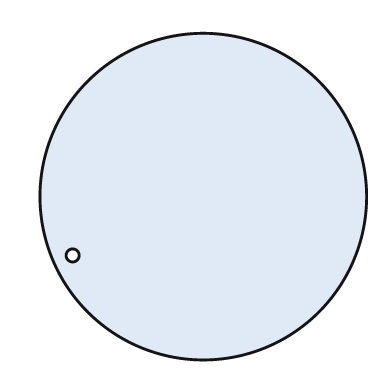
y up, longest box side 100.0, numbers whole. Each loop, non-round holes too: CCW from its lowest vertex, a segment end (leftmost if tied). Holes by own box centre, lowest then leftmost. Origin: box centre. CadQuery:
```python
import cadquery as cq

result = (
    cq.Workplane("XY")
    .moveTo(0.0, 0.0)
    .circle(50.0)
    .moveTo(-40.0, -18.0)
    .circle(2.0)
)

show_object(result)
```